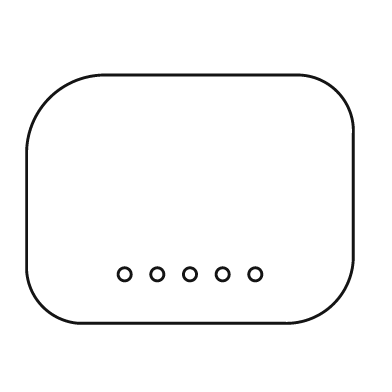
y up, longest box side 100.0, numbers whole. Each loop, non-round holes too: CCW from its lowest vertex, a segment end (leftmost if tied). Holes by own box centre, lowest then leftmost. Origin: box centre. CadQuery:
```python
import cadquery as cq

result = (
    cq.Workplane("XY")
    .moveTo(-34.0, -38.0)
    .lineTo(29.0, -38.0)
    .threePointArc((44.0, -32.0), (50.0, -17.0))
    .lineTo(50.0, 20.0)
    .threePointArc((45.0, 33.0), (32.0, 38.0))
    .lineTo(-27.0, 38.0)
    .threePointArc((-43.0, 31.0), (-50.0, 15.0))
    .lineTo(-50.0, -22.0)
    .threePointArc((-45.0, -33.0), (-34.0, -38.0))
    .close()
    .moveTo(-20.0, -23.0)
    .circle(2.0)
    .moveTo(-10.0, -23.0)
    .circle(2.0)
    .moveTo(0.0, -23.0)
    .circle(2.0)
    .moveTo(10.0, -23.0)
    .circle(2.0)
    .moveTo(20.0, -23.0)
    .circle(2.0)
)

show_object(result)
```